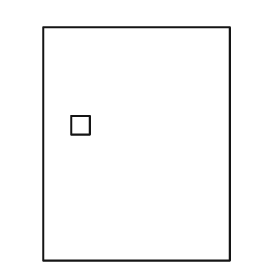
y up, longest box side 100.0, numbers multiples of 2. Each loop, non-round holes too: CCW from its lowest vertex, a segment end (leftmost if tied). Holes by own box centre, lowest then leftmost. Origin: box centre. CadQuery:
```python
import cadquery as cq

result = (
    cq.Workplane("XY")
    .moveTo(-40.0, -50.0)
    .lineTo(40.0, -50.0)
    .lineTo(40.0, 50.0)
    .lineTo(-40.0, 50.0)
    .close()
    .moveTo(-28.0, 4.0)
    .lineTo(-20.0, 4.0)
    .lineTo(-20.0, 12.0)
    .lineTo(-28.0, 12.0)
    .close()
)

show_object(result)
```